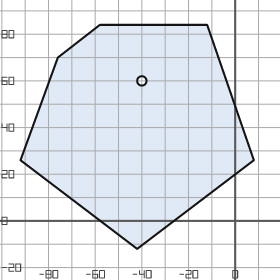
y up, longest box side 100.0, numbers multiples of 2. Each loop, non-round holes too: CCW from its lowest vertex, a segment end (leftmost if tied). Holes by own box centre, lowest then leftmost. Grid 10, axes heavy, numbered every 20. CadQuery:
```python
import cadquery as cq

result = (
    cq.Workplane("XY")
    .moveTo(-42.0, -12.0)
    .lineTo(8.0, 26.0)
    .lineTo(-12.0, 84.0)
    .lineTo(-58.0, 84.0)
    .lineTo(-76.0, 70.0)
    .lineTo(-92.0, 26.0)
    .close()
    .moveTo(-40.0, 60.0)
    .circle(2.0)
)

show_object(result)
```